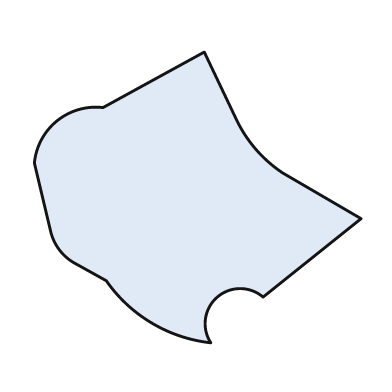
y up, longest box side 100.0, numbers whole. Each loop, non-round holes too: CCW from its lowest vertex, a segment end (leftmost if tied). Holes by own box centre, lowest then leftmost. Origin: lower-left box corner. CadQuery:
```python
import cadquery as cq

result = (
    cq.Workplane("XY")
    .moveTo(54.0, 0.0)
    .threePointArc((56.0, 14.0), (70.0, 14.0))
    .lineTo(100.0, 38.0)
    .lineTo(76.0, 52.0)
    .threePointArc((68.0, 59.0), (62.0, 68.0))
    .lineTo(52.0, 89.0)
    .lineTo(21.0, 72.0)
    .threePointArc((7.0, 68.0), (0.0, 55.0))
    .lineTo(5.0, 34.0)
    .threePointArc((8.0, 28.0), (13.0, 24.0))
    .lineTo(22.0, 19.0)
    .threePointArc((36.0, 6.0), (54.0, 0.0))
    .close()
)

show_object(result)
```